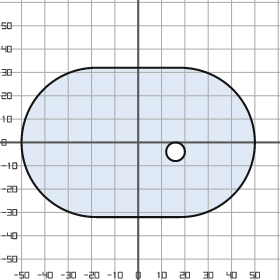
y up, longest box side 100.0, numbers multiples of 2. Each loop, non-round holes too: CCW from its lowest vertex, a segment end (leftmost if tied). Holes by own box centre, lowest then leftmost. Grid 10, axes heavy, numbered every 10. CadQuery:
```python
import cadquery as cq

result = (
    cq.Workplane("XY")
    .moveTo(-18.0, -32.0)
    .lineTo(18.0, -32.0)
    .threePointArc((50.0, 0.0), (18.0, 32.0))
    .lineTo(-18.0, 32.0)
    .threePointArc((-50.0, 0.0), (-18.0, -32.0))
    .close()
    .moveTo(16.0, -4.0)
    .circle(4.0)
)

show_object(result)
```